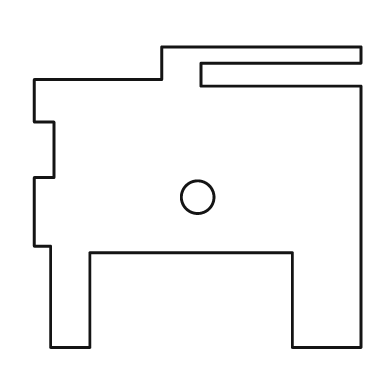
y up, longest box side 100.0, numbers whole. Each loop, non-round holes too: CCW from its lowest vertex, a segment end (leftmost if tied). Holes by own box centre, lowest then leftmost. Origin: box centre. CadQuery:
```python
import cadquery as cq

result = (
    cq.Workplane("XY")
    .moveTo(-45.0, -46.0)
    .lineTo(-33.0, -46.0)
    .lineTo(-33.0, -17.0)
    .lineTo(29.0, -17.0)
    .lineTo(29.0, -46.0)
    .lineTo(50.0, -46.0)
    .lineTo(50.0, 34.0)
    .lineTo(1.0, 34.0)
    .lineTo(1.0, 41.0)
    .lineTo(50.0, 41.0)
    .lineTo(50.0, 46.0)
    .lineTo(-11.0, 46.0)
    .lineTo(-11.0, 36.0)
    .lineTo(-50.0, 36.0)
    .lineTo(-50.0, 23.0)
    .lineTo(-44.0, 23.0)
    .lineTo(-44.0, 6.0)
    .lineTo(-50.0, 6.0)
    .lineTo(-50.0, -15.0)
    .lineTo(-45.0, -15.0)
    .close()
    .moveTo(0.0, 0.0)
    .circle(5.0)
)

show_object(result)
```